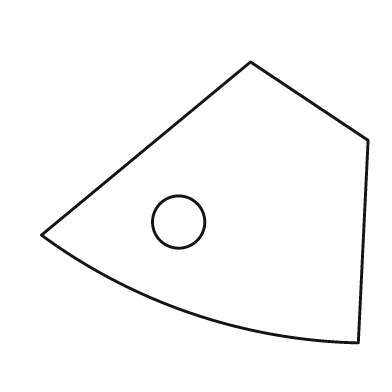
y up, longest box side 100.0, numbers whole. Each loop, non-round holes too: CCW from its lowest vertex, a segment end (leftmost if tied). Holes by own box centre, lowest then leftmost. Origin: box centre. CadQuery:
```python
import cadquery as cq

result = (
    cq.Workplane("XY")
    .moveTo(47.0, -43.0)
    .lineTo(50.0, 19.0)
    .lineTo(14.0, 43.0)
    .lineTo(-50.0, -10.0)
    .threePointArc((-4.0, -34.0), (47.0, -43.0))
    .close()
    .moveTo(-8.0, -6.0)
    .circle(8.0)
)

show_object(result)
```